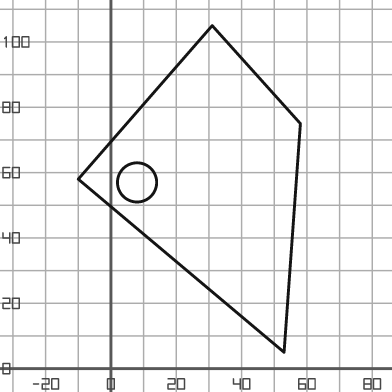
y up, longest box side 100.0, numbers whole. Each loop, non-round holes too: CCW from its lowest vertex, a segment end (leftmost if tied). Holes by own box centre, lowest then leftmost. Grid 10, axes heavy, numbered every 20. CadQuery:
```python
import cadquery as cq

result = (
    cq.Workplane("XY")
    .moveTo(53.0, 5.0)
    .lineTo(58.0, 75.0)
    .lineTo(31.0, 105.0)
    .lineTo(-10.0, 58.0)
    .close()
    .moveTo(8.0, 57.0)
    .circle(6.0)
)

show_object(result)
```